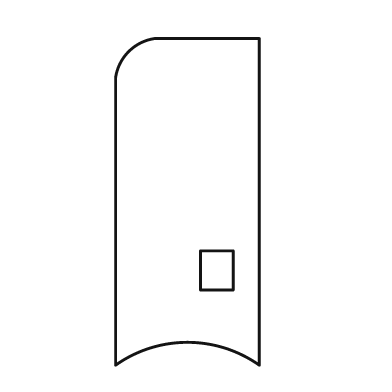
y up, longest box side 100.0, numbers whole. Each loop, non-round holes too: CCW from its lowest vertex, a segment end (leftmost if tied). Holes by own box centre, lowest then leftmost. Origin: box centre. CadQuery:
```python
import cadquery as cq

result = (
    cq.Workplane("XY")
    .moveTo(-22.0, -50.0)
    .threePointArc((0.0, -43.0), (22.0, -50.0))
    .lineTo(22.0, 50.0)
    .lineTo(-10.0, 50.0)
    .threePointArc((-18.0, 46.0), (-22.0, 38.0))
    .close()
    .moveTo(4.0, -27.0)
    .lineTo(14.0, -27.0)
    .lineTo(14.0, -15.0)
    .lineTo(4.0, -15.0)
    .close()
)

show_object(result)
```